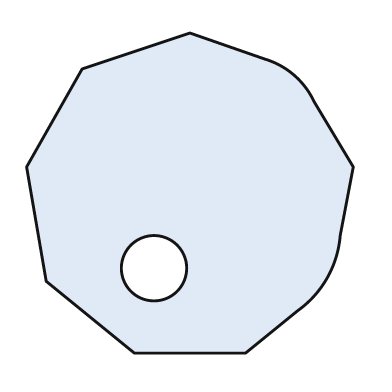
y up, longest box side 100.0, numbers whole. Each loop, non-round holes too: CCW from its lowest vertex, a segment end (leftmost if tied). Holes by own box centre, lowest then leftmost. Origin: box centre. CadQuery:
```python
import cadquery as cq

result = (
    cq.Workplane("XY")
    .moveTo(-17.0, -49.0)
    .lineTo(17.0, -49.0)
    .lineTo(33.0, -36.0)
    .threePointArc((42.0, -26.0), (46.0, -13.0))
    .lineTo(50.0, 8.0)
    .lineTo(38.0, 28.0)
    .threePointArc((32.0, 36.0), (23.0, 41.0))
    .lineTo(0.0, 49.0)
    .lineTo(-33.0, 38.0)
    .lineTo(-50.0, 8.0)
    .lineTo(-44.0, -27.0)
    .close()
    .moveTo(-11.0, -23.0)
    .circle(10.0)
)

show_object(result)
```